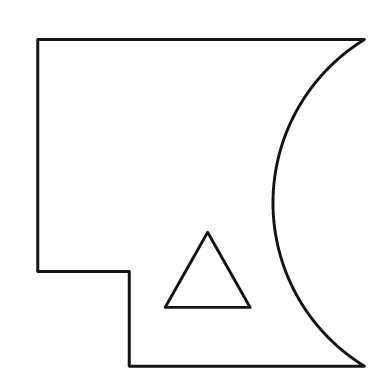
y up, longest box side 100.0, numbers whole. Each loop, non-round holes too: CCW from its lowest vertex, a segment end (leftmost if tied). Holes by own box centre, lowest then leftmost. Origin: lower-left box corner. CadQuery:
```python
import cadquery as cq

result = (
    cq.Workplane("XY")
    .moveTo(28.0, 0.0)
    .lineTo(100.0, 0.0)
    .threePointArc((72.0, 50.0), (100.0, 100.0))
    .lineTo(0.0, 100.0)
    .lineTo(0.0, 29.0)
    .lineTo(28.0, 29.0)
    .close()
    .moveTo(39.0, 18.0)
    .lineTo(65.0, 18.0)
    .lineTo(52.0, 41.0)
    .close()
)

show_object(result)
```